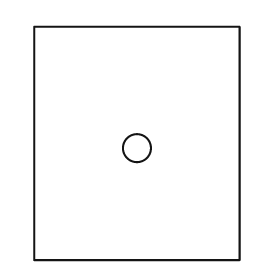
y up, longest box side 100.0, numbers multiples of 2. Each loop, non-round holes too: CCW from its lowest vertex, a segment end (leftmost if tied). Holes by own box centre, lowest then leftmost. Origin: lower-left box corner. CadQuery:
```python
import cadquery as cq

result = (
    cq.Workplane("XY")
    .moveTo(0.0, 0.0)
    .lineTo(88.0, 0.0)
    .lineTo(88.0, 100.0)
    .lineTo(0.0, 100.0)
    .close()
    .moveTo(44.0, 48.0)
    .circle(6.0)
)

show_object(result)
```